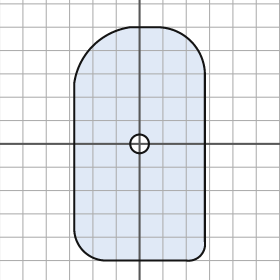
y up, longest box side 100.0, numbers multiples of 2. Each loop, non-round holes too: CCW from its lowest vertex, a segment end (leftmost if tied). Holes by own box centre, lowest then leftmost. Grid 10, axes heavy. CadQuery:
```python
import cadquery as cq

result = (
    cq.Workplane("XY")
    .moveTo(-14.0, -50.0)
    .lineTo(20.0, -50.0)
    .threePointArc((26.0, -48.0), (28.0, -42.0))
    .lineTo(28.0, 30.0)
    .threePointArc((22.0, 44.0), (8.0, 50.0))
    .lineTo(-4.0, 50.0)
    .threePointArc((-20.0, 42.0), (-28.0, 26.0))
    .lineTo(-28.0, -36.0)
    .threePointArc((-24.0, -46.0), (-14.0, -50.0))
    .close()
    .moveTo(0.0, 0.0)
    .circle(4.0)
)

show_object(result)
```